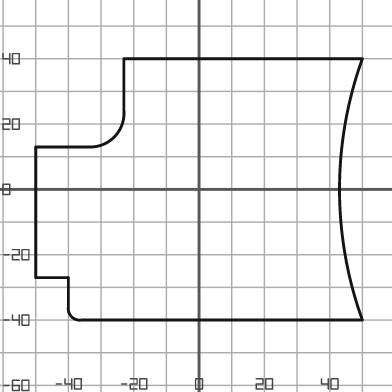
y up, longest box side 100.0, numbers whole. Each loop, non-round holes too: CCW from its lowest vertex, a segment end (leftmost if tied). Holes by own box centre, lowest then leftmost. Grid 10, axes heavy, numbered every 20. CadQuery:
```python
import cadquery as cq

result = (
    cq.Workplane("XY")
    .moveTo(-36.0, -40.0)
    .lineTo(50.0, -40.0)
    .threePointArc((43.0, 0.0), (50.0, 40.0))
    .lineTo(-23.0, 40.0)
    .lineTo(-23.0, 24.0)
    .threePointArc((-26.0, 16.0), (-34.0, 13.0))
    .lineTo(-50.0, 13.0)
    .lineTo(-50.0, -27.0)
    .lineTo(-40.0, -27.0)
    .lineTo(-40.0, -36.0)
    .threePointArc((-39.0, -39.0), (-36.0, -40.0))
    .close()
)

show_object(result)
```